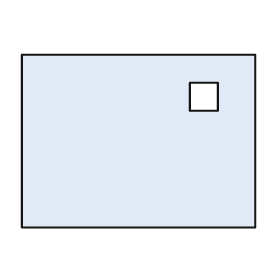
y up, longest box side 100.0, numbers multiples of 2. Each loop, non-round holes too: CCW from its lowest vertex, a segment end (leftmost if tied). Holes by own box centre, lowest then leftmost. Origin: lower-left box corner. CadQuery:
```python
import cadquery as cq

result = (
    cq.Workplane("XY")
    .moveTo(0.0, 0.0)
    .lineTo(100.0, 0.0)
    .lineTo(100.0, 74.0)
    .lineTo(0.0, 74.0)
    .close()
    .moveTo(72.0, 50.0)
    .lineTo(84.0, 50.0)
    .lineTo(84.0, 62.0)
    .lineTo(72.0, 62.0)
    .close()
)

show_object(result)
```